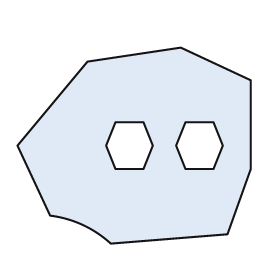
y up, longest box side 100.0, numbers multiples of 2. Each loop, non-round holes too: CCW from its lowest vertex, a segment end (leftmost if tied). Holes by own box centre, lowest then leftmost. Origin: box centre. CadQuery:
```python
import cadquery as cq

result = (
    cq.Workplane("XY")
    .moveTo(-10.0, -42.0)
    .lineTo(40.0, -38.0)
    .lineTo(50.0, -10.0)
    .lineTo(50.0, 28.0)
    .lineTo(20.0, 42.0)
    .lineTo(-20.0, 36.0)
    .lineTo(-50.0, 0.0)
    .lineTo(-36.0, -30.0)
    .threePointArc((-22.0, -34.0), (-10.0, -42.0))
    .close()
    .moveTo(-8.0, -10.0)
    .lineTo(4.0, -10.0)
    .lineTo(8.0, 0.0)
    .lineTo(4.0, 10.0)
    .lineTo(-8.0, 10.0)
    .lineTo(-12.0, 0.0)
    .close()
    .moveTo(22.0, -10.0)
    .lineTo(34.0, -10.0)
    .lineTo(38.0, 0.0)
    .lineTo(34.0, 10.0)
    .lineTo(22.0, 10.0)
    .lineTo(18.0, 0.0)
    .close()
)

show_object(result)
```